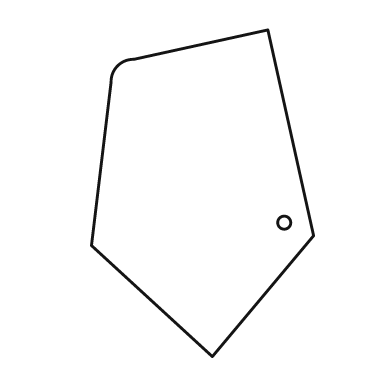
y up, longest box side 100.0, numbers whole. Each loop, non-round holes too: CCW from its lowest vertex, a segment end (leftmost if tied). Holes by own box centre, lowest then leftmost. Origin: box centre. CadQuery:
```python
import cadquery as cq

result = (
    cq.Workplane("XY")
    .moveTo(3.0, -50.0)
    .lineTo(34.0, -13.0)
    .lineTo(20.0, 50.0)
    .lineTo(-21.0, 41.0)
    .threePointArc((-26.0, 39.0), (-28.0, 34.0))
    .lineTo(-34.0, -16.0)
    .close()
    .moveTo(25.0, -9.0)
    .circle(2.0)
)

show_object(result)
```